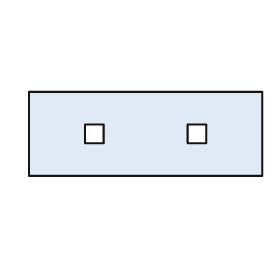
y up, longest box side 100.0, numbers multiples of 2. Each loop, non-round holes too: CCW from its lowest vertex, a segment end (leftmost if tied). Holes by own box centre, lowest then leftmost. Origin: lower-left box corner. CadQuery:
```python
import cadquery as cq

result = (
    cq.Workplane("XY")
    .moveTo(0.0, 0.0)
    .lineTo(100.0, 0.0)
    .lineTo(100.0, 36.0)
    .lineTo(0.0, 36.0)
    .close()
    .moveTo(24.0, 14.0)
    .lineTo(32.0, 14.0)
    .lineTo(32.0, 22.0)
    .lineTo(24.0, 22.0)
    .close()
    .moveTo(68.0, 14.0)
    .lineTo(76.0, 14.0)
    .lineTo(76.0, 22.0)
    .lineTo(68.0, 22.0)
    .close()
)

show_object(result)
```